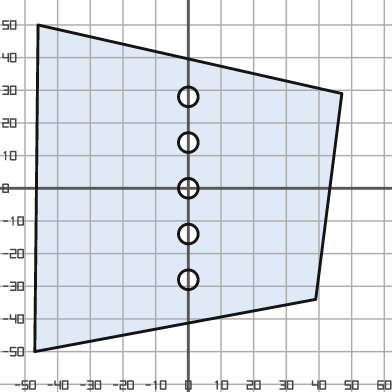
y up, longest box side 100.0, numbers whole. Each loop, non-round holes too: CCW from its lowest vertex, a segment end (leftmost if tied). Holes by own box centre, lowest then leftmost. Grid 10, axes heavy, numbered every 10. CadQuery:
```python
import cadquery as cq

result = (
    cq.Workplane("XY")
    .moveTo(-47.0, -50.0)
    .lineTo(39.0, -34.0)
    .lineTo(47.0, 29.0)
    .lineTo(-46.0, 50.0)
    .close()
    .moveTo(0.0, -28.0)
    .circle(3.0)
    .moveTo(0.0, -14.0)
    .circle(3.0)
    .moveTo(0.0, 0.0)
    .circle(3.0)
    .moveTo(0.0, 14.0)
    .circle(3.0)
    .moveTo(0.0, 28.0)
    .circle(3.0)
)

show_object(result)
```